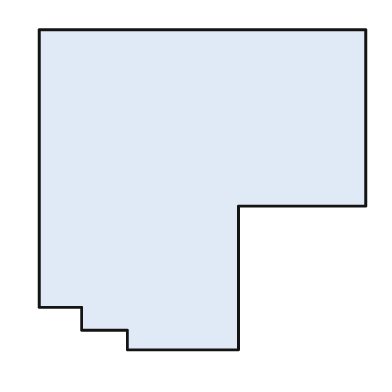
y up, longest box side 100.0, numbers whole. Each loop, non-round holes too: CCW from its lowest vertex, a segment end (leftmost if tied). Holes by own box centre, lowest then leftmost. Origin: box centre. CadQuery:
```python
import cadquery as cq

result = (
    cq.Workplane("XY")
    .moveTo(-23.0, -49.0)
    .lineTo(11.0, -49.0)
    .lineTo(11.0, -5.0)
    .lineTo(50.0, -5.0)
    .lineTo(50.0, 49.0)
    .lineTo(-50.0, 49.0)
    .lineTo(-50.0, -36.0)
    .lineTo(-37.0, -36.0)
    .lineTo(-37.0, -43.0)
    .lineTo(-23.0, -43.0)
    .close()
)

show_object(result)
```